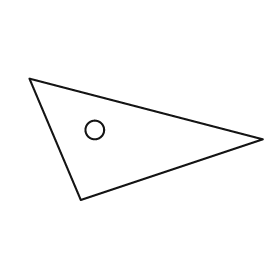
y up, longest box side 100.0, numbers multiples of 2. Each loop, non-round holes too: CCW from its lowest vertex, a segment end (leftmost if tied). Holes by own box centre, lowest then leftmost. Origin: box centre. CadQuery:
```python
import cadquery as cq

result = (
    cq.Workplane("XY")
    .moveTo(-28.0, -26.0)
    .lineTo(50.0, 0.0)
    .lineTo(-50.0, 26.0)
    .close()
    .moveTo(-22.0, 4.0)
    .circle(4.0)
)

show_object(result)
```